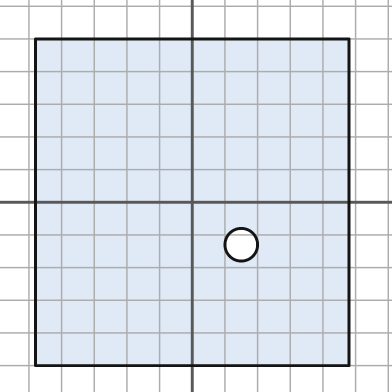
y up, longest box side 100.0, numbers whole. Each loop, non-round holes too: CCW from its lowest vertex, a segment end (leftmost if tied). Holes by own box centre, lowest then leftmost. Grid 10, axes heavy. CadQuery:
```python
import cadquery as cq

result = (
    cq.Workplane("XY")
    .moveTo(-48.0, -50.0)
    .lineTo(48.0, -50.0)
    .lineTo(48.0, 50.0)
    .lineTo(-48.0, 50.0)
    .close()
    .moveTo(15.0, -13.0)
    .circle(5.0)
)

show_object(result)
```